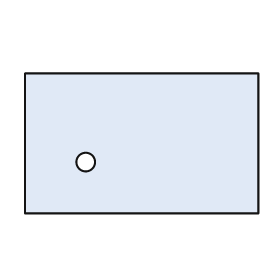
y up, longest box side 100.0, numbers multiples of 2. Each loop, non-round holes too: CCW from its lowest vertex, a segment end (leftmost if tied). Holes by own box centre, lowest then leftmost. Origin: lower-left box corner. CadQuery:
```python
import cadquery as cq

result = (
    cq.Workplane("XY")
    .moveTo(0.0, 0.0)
    .lineTo(100.0, 0.0)
    .lineTo(100.0, 60.0)
    .lineTo(0.0, 60.0)
    .close()
    .moveTo(26.0, 22.0)
    .circle(4.0)
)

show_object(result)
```